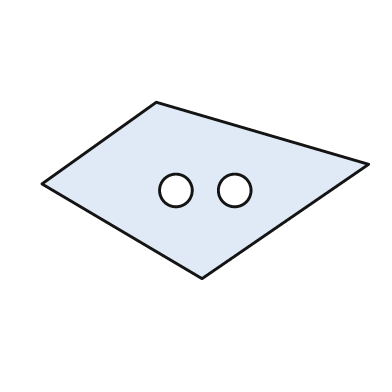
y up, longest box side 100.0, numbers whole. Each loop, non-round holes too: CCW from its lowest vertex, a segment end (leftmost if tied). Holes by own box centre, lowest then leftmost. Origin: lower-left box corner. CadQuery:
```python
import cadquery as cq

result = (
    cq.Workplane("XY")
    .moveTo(49.0, 0.0)
    .lineTo(100.0, 35.0)
    .lineTo(35.0, 54.0)
    .lineTo(0.0, 29.0)
    .close()
    .moveTo(41.0, 27.0)
    .circle(5.0)
    .moveTo(59.0, 27.0)
    .circle(5.0)
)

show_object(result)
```